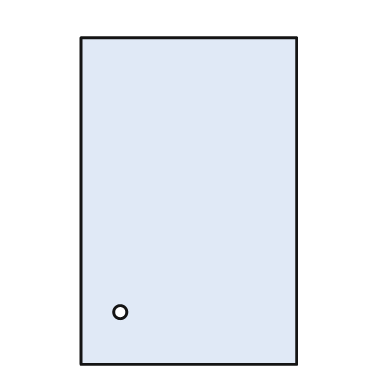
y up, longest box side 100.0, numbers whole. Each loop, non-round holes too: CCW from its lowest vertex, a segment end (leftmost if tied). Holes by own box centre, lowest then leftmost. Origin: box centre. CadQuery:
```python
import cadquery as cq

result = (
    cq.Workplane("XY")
    .moveTo(-33.0, -50.0)
    .lineTo(33.0, -50.0)
    .lineTo(33.0, 50.0)
    .lineTo(-33.0, 50.0)
    .close()
    .moveTo(-21.0, -34.0)
    .circle(2.0)
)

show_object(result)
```